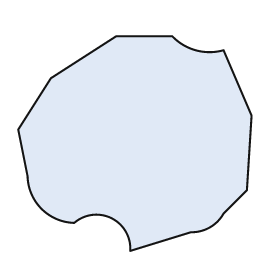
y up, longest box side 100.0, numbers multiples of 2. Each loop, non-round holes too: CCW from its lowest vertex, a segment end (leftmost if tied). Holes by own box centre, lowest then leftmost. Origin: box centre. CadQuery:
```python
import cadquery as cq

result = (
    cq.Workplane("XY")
    .moveTo(-2.0, -46.0)
    .lineTo(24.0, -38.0)
    .threePointArc((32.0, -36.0), (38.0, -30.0))
    .lineTo(48.0, -20.0)
    .lineTo(50.0, 12.0)
    .lineTo(38.0, 40.0)
    .threePointArc((26.0, 40.0), (16.0, 46.0))
    .lineTo(-8.0, 46.0)
    .lineTo(-36.0, 28.0)
    .lineTo(-50.0, 6.0)
    .lineTo(-46.0, -14.0)
    .threePointArc((-40.0, -28.0), (-26.0, -34.0))
    .threePointArc((-10.0, -32.0), (-2.0, -46.0))
    .close()
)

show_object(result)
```